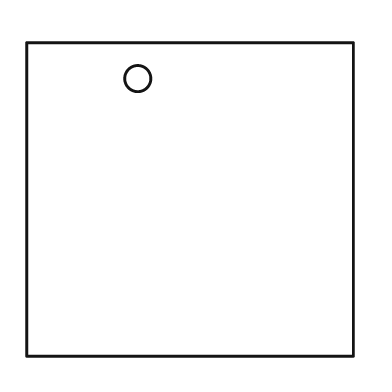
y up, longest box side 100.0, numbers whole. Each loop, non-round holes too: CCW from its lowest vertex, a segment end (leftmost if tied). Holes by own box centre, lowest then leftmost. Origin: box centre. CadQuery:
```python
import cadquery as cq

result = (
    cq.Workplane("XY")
    .moveTo(-50.0, -48.0)
    .lineTo(50.0, -48.0)
    .lineTo(50.0, 48.0)
    .lineTo(-50.0, 48.0)
    .close()
    .moveTo(-16.0, 37.0)
    .circle(4.0)
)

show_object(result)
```